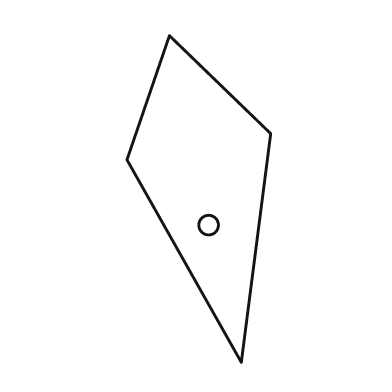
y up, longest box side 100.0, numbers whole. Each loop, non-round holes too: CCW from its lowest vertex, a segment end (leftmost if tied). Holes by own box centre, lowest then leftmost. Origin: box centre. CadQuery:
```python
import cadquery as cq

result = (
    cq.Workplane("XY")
    .moveTo(13.0, -50.0)
    .lineTo(22.0, 20.0)
    .lineTo(-9.0, 50.0)
    .lineTo(-22.0, 12.0)
    .close()
    .moveTo(3.0, -8.0)
    .circle(3.0)
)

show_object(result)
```